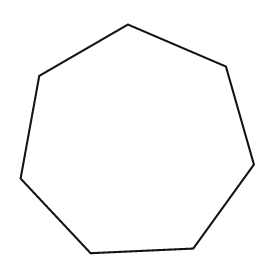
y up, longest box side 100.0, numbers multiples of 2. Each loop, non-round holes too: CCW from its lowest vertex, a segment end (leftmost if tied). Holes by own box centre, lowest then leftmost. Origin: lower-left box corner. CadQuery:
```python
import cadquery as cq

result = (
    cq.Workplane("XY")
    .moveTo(30.0, 0.0)
    .lineTo(74.0, 2.0)
    .lineTo(100.0, 38.0)
    .lineTo(88.0, 80.0)
    .lineTo(46.0, 98.0)
    .lineTo(8.0, 76.0)
    .lineTo(0.0, 32.0)
    .close()
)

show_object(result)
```